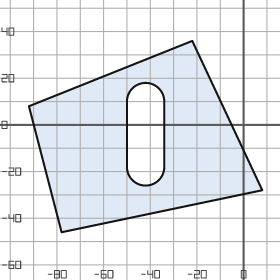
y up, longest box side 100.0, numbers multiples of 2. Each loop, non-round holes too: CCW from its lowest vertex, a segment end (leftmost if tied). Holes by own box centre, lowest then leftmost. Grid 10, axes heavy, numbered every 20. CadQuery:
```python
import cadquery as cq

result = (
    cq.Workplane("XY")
    .moveTo(-78.0, -46.0)
    .lineTo(8.0, -28.0)
    .lineTo(-22.0, 36.0)
    .lineTo(-92.0, 8.0)
    .close()
    .moveTo(-50.0, -18.0)
    .threePointArc((-42.0, -26.0), (-34.0, -18.0))
    .lineTo(-34.0, 10.0)
    .threePointArc((-42.0, 18.0), (-50.0, 10.0))
    .close()
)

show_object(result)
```